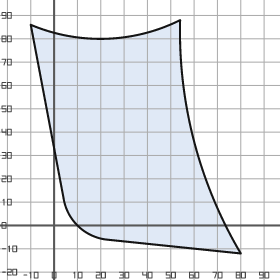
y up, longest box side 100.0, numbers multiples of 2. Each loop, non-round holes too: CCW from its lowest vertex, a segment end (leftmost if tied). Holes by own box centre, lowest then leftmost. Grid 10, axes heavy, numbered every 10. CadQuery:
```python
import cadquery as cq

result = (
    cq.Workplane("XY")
    .moveTo(80.0, -12.0)
    .threePointArc((60.0, 36.0), (54.0, 88.0))
    .threePointArc((22.0, 80.0), (-10.0, 86.0))
    .lineTo(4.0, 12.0)
    .threePointArc((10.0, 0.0), (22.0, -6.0))
    .close()
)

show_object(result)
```